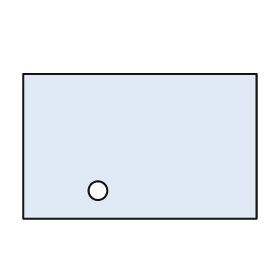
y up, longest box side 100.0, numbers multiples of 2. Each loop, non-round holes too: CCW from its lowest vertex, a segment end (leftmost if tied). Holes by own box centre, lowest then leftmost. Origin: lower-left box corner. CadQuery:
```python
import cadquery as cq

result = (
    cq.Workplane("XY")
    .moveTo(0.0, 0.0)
    .lineTo(100.0, 0.0)
    .lineTo(100.0, 62.0)
    .lineTo(0.0, 62.0)
    .close()
    .moveTo(32.0, 12.0)
    .circle(4.0)
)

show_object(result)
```